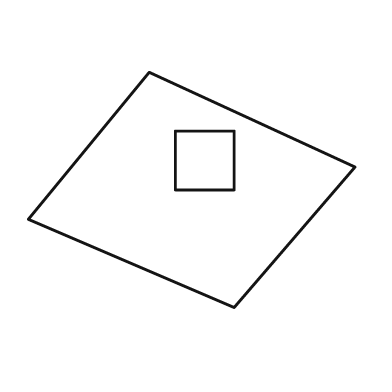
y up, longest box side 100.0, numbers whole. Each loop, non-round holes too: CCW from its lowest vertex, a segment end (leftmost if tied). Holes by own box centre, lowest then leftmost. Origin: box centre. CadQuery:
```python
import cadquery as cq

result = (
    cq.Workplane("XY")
    .moveTo(13.0, -36.0)
    .lineTo(50.0, 7.0)
    .lineTo(-13.0, 36.0)
    .lineTo(-50.0, -9.0)
    .close()
    .moveTo(-5.0, 0.0)
    .lineTo(13.0, 0.0)
    .lineTo(13.0, 18.0)
    .lineTo(-5.0, 18.0)
    .close()
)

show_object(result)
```